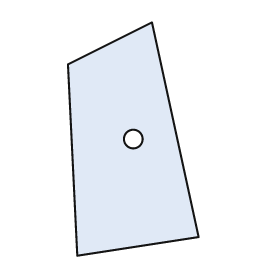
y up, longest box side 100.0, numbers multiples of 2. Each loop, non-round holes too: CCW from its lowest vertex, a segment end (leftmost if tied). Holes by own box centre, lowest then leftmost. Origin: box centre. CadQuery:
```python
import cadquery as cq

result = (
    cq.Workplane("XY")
    .moveTo(-24.0, -50.0)
    .lineTo(28.0, -42.0)
    .lineTo(8.0, 50.0)
    .lineTo(-28.0, 32.0)
    .close()
    .moveTo(0.0, 0.0)
    .circle(4.0)
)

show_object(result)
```